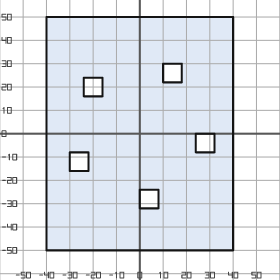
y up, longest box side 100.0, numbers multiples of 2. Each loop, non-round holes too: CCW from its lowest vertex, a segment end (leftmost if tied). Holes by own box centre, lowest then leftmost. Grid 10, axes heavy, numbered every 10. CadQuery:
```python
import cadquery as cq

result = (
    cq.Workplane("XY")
    .moveTo(-40.0, -50.0)
    .lineTo(40.0, -50.0)
    .lineTo(40.0, 50.0)
    .lineTo(-40.0, 50.0)
    .close()
    .moveTo(0.0, -32.0)
    .lineTo(8.0, -32.0)
    .lineTo(8.0, -24.0)
    .lineTo(0.0, -24.0)
    .close()
    .moveTo(-30.0, -16.0)
    .lineTo(-22.0, -16.0)
    .lineTo(-22.0, -8.0)
    .lineTo(-30.0, -8.0)
    .close()
    .moveTo(24.0, -8.0)
    .lineTo(32.0, -8.0)
    .lineTo(32.0, 0.0)
    .lineTo(24.0, 0.0)
    .close()
    .moveTo(-24.0, 16.0)
    .lineTo(-16.0, 16.0)
    .lineTo(-16.0, 24.0)
    .lineTo(-24.0, 24.0)
    .close()
    .moveTo(10.0, 22.0)
    .lineTo(18.0, 22.0)
    .lineTo(18.0, 30.0)
    .lineTo(10.0, 30.0)
    .close()
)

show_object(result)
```